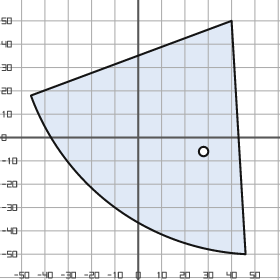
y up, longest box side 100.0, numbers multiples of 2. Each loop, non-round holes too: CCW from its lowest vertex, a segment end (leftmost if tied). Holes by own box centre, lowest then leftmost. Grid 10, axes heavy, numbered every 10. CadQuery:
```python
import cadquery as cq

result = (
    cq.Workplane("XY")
    .moveTo(46.0, -50.0)
    .lineTo(40.0, 50.0)
    .lineTo(-46.0, 18.0)
    .threePointArc((-10.0, -30.0), (46.0, -50.0))
    .close()
    .moveTo(28.0, -6.0)
    .circle(2.0)
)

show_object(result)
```